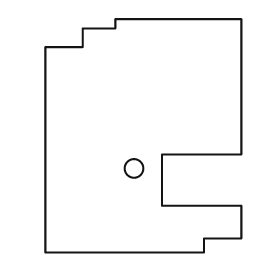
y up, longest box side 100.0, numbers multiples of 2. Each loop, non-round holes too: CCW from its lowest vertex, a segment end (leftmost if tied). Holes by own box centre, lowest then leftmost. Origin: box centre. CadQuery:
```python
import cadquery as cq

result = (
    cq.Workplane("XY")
    .moveTo(-42.0, -50.0)
    .lineTo(26.0, -50.0)
    .lineTo(26.0, -44.0)
    .lineTo(42.0, -44.0)
    .lineTo(42.0, -30.0)
    .lineTo(8.0, -30.0)
    .lineTo(8.0, -8.0)
    .lineTo(42.0, -8.0)
    .lineTo(42.0, 50.0)
    .lineTo(-12.0, 50.0)
    .lineTo(-12.0, 46.0)
    .lineTo(-26.0, 46.0)
    .lineTo(-26.0, 38.0)
    .lineTo(-42.0, 38.0)
    .close()
    .moveTo(-4.0, -14.0)
    .circle(4.0)
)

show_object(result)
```